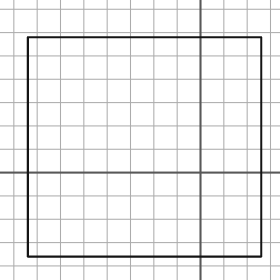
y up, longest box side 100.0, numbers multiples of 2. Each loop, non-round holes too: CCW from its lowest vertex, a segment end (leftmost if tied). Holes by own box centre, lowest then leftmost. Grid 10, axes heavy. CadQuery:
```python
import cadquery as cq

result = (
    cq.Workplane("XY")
    .moveTo(-74.0, -36.0)
    .lineTo(26.0, -36.0)
    .lineTo(26.0, 58.0)
    .lineTo(-74.0, 58.0)
    .close()
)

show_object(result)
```